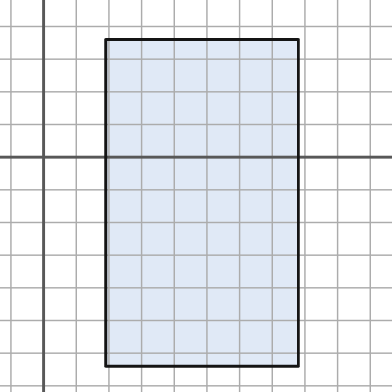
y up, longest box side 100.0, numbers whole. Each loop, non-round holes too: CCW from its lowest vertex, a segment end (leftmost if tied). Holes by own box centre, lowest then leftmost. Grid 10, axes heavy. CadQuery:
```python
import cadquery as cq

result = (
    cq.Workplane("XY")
    .moveTo(19.0, -64.0)
    .lineTo(78.0, -64.0)
    .lineTo(78.0, 36.0)
    .lineTo(19.0, 36.0)
    .close()
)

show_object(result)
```